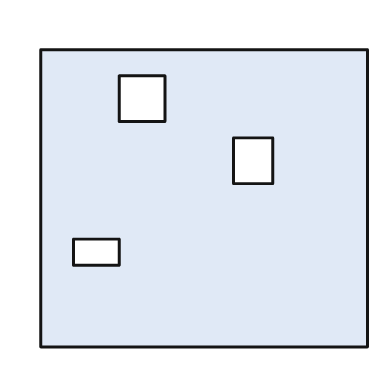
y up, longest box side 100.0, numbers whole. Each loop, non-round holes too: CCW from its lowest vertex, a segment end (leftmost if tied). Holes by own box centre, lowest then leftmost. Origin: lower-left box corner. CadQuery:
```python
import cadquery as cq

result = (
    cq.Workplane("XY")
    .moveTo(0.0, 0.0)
    .lineTo(100.0, 0.0)
    .lineTo(100.0, 91.0)
    .lineTo(0.0, 91.0)
    .close()
    .moveTo(10.0, 25.0)
    .lineTo(24.0, 25.0)
    .lineTo(24.0, 33.0)
    .lineTo(10.0, 33.0)
    .close()
    .moveTo(59.0, 50.0)
    .lineTo(71.0, 50.0)
    .lineTo(71.0, 64.0)
    .lineTo(59.0, 64.0)
    .close()
    .moveTo(24.0, 69.0)
    .lineTo(38.0, 69.0)
    .lineTo(38.0, 83.0)
    .lineTo(24.0, 83.0)
    .close()
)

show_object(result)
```